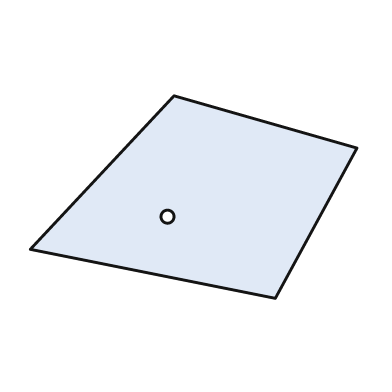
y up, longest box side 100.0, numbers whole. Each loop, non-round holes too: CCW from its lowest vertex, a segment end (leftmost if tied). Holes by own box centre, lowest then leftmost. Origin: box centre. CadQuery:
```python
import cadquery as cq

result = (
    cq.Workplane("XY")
    .moveTo(25.0, -31.0)
    .lineTo(50.0, 15.0)
    .lineTo(-6.0, 31.0)
    .lineTo(-50.0, -16.0)
    .close()
    .moveTo(-8.0, -6.0)
    .circle(2.0)
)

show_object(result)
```